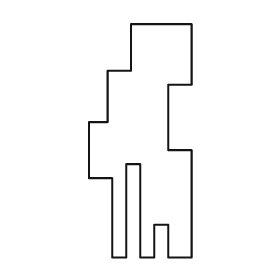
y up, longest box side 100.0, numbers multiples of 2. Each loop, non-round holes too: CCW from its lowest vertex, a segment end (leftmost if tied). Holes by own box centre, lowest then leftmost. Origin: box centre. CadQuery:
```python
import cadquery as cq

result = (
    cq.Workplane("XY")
    .moveTo(-12.0, -50.0)
    .lineTo(-6.0, -50.0)
    .lineTo(-6.0, -10.0)
    .lineTo(0.0, -10.0)
    .lineTo(0.0, -50.0)
    .lineTo(6.0, -50.0)
    .lineTo(6.0, -36.0)
    .lineTo(12.0, -36.0)
    .lineTo(12.0, -50.0)
    .lineTo(22.0, -50.0)
    .lineTo(22.0, -4.0)
    .lineTo(12.0, -4.0)
    .lineTo(12.0, 24.0)
    .lineTo(22.0, 24.0)
    .lineTo(22.0, 50.0)
    .lineTo(-4.0, 50.0)
    .lineTo(-4.0, 30.0)
    .lineTo(-14.0, 30.0)
    .lineTo(-14.0, 8.0)
    .lineTo(-22.0, 8.0)
    .lineTo(-22.0, -16.0)
    .lineTo(-12.0, -16.0)
    .close()
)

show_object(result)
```